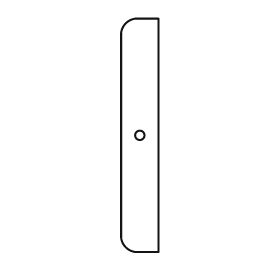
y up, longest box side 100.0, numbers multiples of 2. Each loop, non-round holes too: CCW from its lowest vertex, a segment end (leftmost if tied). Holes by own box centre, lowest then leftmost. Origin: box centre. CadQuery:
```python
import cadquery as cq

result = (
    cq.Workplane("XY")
    .moveTo(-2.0, -50.0)
    .lineTo(8.0, -50.0)
    .lineTo(8.0, 50.0)
    .lineTo(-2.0, 50.0)
    .threePointArc((-6.0, 48.0), (-8.0, 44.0))
    .lineTo(-8.0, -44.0)
    .threePointArc((-6.0, -48.0), (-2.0, -50.0))
    .close()
    .moveTo(0.0, 0.0)
    .circle(2.0)
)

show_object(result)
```